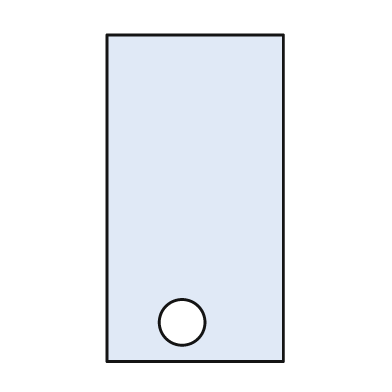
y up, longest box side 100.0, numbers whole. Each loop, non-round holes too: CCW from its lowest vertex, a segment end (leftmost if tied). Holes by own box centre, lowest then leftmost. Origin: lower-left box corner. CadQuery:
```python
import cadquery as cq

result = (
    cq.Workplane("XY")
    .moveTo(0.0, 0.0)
    .lineTo(54.0, 0.0)
    .lineTo(54.0, 100.0)
    .lineTo(0.0, 100.0)
    .close()
    .moveTo(23.0, 12.0)
    .circle(7.0)
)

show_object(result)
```